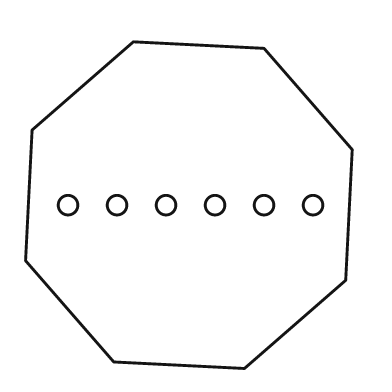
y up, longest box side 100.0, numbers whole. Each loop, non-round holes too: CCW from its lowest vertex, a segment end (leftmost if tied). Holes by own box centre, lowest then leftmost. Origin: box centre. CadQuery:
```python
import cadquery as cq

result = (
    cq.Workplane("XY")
    .moveTo(17.0, -50.0)
    .lineTo(48.0, -23.0)
    .lineTo(50.0, 17.0)
    .lineTo(23.0, 48.0)
    .lineTo(-17.0, 50.0)
    .lineTo(-48.0, 23.0)
    .lineTo(-50.0, -17.0)
    .lineTo(-23.0, -48.0)
    .close()
    .moveTo(-37.0, 0.0)
    .circle(3.0)
    .moveTo(-22.0, 0.0)
    .circle(3.0)
    .moveTo(-7.0, 0.0)
    .circle(3.0)
    .moveTo(8.0, 0.0)
    .circle(3.0)
    .moveTo(23.0, 0.0)
    .circle(3.0)
    .moveTo(38.0, 0.0)
    .circle(3.0)
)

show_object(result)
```